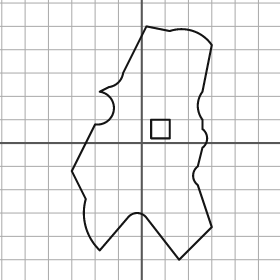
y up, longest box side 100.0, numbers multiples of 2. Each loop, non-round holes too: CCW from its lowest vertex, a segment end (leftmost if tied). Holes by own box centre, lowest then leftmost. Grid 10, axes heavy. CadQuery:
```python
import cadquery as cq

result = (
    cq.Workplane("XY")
    .moveTo(16.0, -50.0)
    .lineTo(30.0, -36.0)
    .lineTo(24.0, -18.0)
    .threePointArc((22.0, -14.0), (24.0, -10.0))
    .lineTo(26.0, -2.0)
    .threePointArc((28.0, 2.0), (26.0, 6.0))
    .lineTo(26.0, 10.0)
    .threePointArc((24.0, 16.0), (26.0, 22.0))
    .lineTo(30.0, 42.0)
    .threePointArc((22.0, 48.0), (12.0, 48.0))
    .lineTo(2.0, 50.0)
    .lineTo(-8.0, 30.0)
    .threePointArc((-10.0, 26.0), (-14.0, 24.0))
    .lineTo(-18.0, 22.0)
    .threePointArc((-12.0, 14.0), (-20.0, 8.0))
    .lineTo(-30.0, -12.0)
    .lineTo(-24.0, -24.0)
    .threePointArc((-24.0, -36.0), (-18.0, -46.0))
    .lineTo(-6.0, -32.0)
    .threePointArc((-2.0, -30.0), (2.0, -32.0))
    .close()
    .moveTo(4.0, 2.0)
    .lineTo(12.0, 2.0)
    .lineTo(12.0, 10.0)
    .lineTo(4.0, 10.0)
    .close()
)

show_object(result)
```